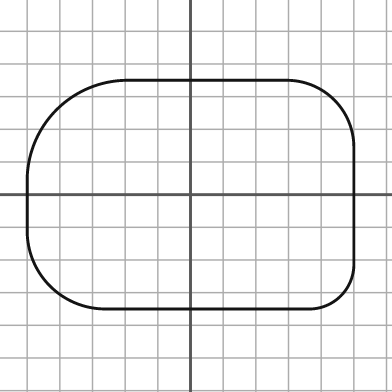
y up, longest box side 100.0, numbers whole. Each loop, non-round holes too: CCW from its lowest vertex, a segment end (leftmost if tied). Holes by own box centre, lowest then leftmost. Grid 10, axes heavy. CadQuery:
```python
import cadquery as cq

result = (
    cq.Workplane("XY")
    .moveTo(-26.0, -35.0)
    .lineTo(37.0, -35.0)
    .threePointArc((46.0, -31.0), (50.0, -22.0))
    .lineTo(50.0, 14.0)
    .threePointArc((44.0, 29.0), (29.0, 35.0))
    .lineTo(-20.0, 35.0)
    .threePointArc((-41.0, 26.0), (-50.0, 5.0))
    .lineTo(-50.0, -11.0)
    .threePointArc((-43.0, -28.0), (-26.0, -35.0))
    .close()
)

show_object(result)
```